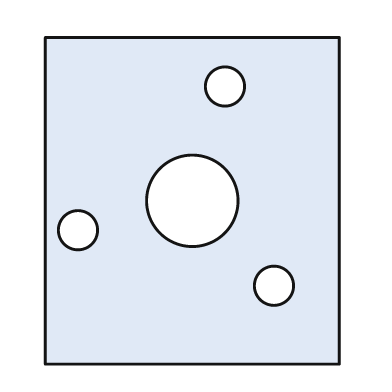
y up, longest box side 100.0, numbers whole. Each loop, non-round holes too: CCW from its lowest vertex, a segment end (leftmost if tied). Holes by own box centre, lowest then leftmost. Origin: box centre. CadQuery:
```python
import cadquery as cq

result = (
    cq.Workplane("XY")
    .moveTo(-45.0, -50.0)
    .lineTo(45.0, -50.0)
    .lineTo(45.0, 50.0)
    .lineTo(-45.0, 50.0)
    .close()
    .moveTo(25.0, -26.0)
    .circle(6.0)
    .moveTo(-35.0, -9.0)
    .circle(6.0)
    .moveTo(0.0, 0.0)
    .circle(14.0)
    .moveTo(10.0, 35.0)
    .circle(6.0)
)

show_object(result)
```